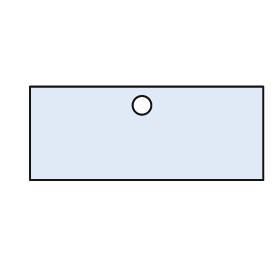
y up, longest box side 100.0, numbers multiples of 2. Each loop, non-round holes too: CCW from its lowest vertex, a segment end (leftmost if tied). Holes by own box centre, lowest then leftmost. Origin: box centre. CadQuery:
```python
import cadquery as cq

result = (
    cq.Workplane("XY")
    .moveTo(-50.0, -20.0)
    .lineTo(50.0, -20.0)
    .lineTo(50.0, 20.0)
    .lineTo(-50.0, 20.0)
    .close()
    .moveTo(-2.0, 12.0)
    .circle(4.0)
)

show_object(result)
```